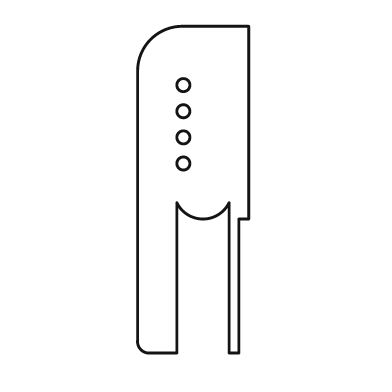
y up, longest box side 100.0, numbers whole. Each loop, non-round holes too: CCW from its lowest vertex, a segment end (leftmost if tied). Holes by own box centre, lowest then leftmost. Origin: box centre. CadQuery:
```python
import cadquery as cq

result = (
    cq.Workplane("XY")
    .moveTo(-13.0, -50.0)
    .lineTo(-5.0, -50.0)
    .lineTo(-5.0, -4.0)
    .threePointArc((3.0, -9.0), (11.0, -4.0))
    .lineTo(11.0, -50.0)
    .lineTo(14.0, -50.0)
    .lineTo(14.0, -9.0)
    .lineTo(17.0, -9.0)
    .lineTo(17.0, 50.0)
    .lineTo(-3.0, 50.0)
    .threePointArc((-13.0, 46.0), (-17.0, 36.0))
    .lineTo(-17.0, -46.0)
    .threePointArc((-16.0, -49.0), (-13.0, -50.0))
    .close()
    .moveTo(-3.0, 8.0)
    .circle(2.0)
    .moveTo(-3.0, 16.0)
    .circle(2.0)
    .moveTo(-3.0, 24.0)
    .circle(2.0)
    .moveTo(-3.0, 32.0)
    .circle(2.0)
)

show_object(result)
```